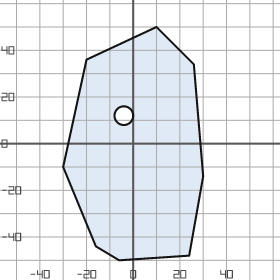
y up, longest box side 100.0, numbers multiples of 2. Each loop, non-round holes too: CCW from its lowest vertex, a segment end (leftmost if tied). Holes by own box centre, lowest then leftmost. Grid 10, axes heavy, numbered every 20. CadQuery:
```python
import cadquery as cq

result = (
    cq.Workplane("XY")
    .moveTo(-6.0, -50.0)
    .lineTo(24.0, -48.0)
    .lineTo(30.0, -14.0)
    .lineTo(26.0, 34.0)
    .lineTo(10.0, 50.0)
    .lineTo(-20.0, 36.0)
    .lineTo(-30.0, -10.0)
    .lineTo(-16.0, -44.0)
    .close()
    .moveTo(-4.0, 12.0)
    .circle(4.0)
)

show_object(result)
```